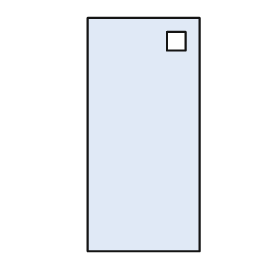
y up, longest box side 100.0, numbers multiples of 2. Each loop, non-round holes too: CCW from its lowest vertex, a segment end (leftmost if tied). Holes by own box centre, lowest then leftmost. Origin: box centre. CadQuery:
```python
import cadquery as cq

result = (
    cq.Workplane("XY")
    .moveTo(-24.0, -50.0)
    .lineTo(24.0, -50.0)
    .lineTo(24.0, 50.0)
    .lineTo(-24.0, 50.0)
    .close()
    .moveTo(10.0, 36.0)
    .lineTo(18.0, 36.0)
    .lineTo(18.0, 44.0)
    .lineTo(10.0, 44.0)
    .close()
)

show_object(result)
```